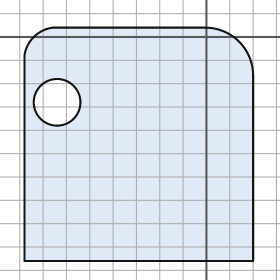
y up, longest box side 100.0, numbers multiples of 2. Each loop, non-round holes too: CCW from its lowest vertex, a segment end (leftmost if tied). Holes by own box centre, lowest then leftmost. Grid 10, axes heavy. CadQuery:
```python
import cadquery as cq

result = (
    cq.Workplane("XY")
    .moveTo(-78.0, -96.0)
    .lineTo(20.0, -96.0)
    .lineTo(20.0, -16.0)
    .threePointArc((14.0, -2.0), (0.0, 4.0))
    .lineTo(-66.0, 4.0)
    .threePointArc((-74.0, 0.0), (-78.0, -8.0))
    .close()
    .moveTo(-64.0, -28.0)
    .circle(10.0)
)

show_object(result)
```